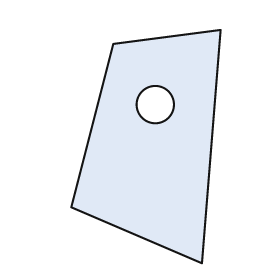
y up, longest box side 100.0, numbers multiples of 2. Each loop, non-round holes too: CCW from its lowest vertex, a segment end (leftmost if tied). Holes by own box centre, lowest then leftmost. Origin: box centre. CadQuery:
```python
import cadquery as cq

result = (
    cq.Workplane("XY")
    .moveTo(24.0, -50.0)
    .lineTo(32.0, 50.0)
    .lineTo(-14.0, 44.0)
    .lineTo(-32.0, -26.0)
    .close()
    .moveTo(4.0, 18.0)
    .circle(8.0)
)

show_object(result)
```